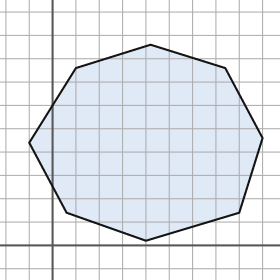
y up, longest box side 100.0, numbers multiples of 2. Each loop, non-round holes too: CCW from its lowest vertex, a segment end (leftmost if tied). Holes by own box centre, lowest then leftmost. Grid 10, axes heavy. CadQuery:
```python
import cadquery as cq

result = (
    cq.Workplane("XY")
    .moveTo(40.0, 2.0)
    .lineTo(80.0, 14.0)
    .lineTo(90.0, 46.0)
    .lineTo(74.0, 76.0)
    .lineTo(42.0, 86.0)
    .lineTo(10.0, 76.0)
    .lineTo(-10.0, 44.0)
    .lineTo(6.0, 14.0)
    .close()
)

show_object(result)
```